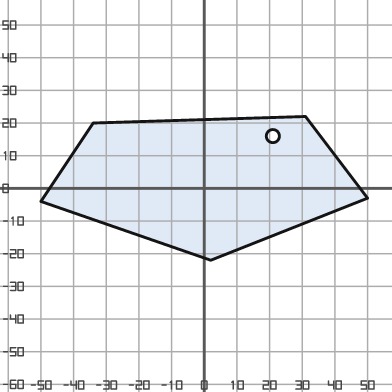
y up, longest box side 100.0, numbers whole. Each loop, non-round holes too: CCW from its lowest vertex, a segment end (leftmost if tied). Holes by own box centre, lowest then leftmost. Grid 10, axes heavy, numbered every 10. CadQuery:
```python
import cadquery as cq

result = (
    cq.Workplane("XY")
    .moveTo(2.0, -22.0)
    .lineTo(50.0, -3.0)
    .lineTo(31.0, 22.0)
    .lineTo(-34.0, 20.0)
    .lineTo(-50.0, -4.0)
    .close()
    .moveTo(21.0, 16.0)
    .circle(2.0)
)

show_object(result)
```